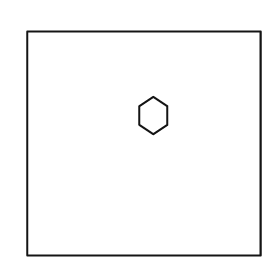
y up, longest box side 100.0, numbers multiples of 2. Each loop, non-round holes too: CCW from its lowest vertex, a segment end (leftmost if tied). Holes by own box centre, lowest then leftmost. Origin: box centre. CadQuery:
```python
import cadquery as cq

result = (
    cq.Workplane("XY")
    .moveTo(-50.0, -48.0)
    .lineTo(50.0, -48.0)
    .lineTo(50.0, 48.0)
    .lineTo(-50.0, 48.0)
    .close()
    .moveTo(4.0, 4.0)
    .lineTo(10.0, 8.0)
    .lineTo(10.0, 16.0)
    .lineTo(4.0, 20.0)
    .lineTo(-2.0, 16.0)
    .lineTo(-2.0, 8.0)
    .close()
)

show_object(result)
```